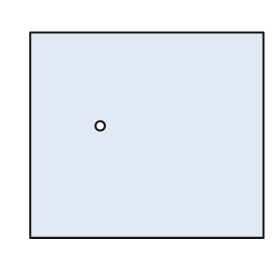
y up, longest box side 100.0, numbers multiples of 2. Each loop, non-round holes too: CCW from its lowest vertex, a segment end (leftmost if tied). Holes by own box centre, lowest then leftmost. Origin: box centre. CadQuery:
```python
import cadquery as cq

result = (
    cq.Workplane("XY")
    .moveTo(-50.0, -44.0)
    .lineTo(50.0, -44.0)
    .lineTo(50.0, 44.0)
    .lineTo(-50.0, 44.0)
    .close()
    .moveTo(-20.0, 4.0)
    .circle(2.0)
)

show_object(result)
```